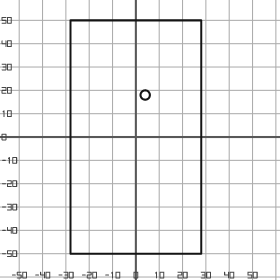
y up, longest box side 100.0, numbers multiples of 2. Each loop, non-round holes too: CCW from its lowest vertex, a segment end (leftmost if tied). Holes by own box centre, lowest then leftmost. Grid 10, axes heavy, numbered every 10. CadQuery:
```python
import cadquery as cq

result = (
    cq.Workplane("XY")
    .moveTo(-28.0, -50.0)
    .lineTo(28.0, -50.0)
    .lineTo(28.0, 50.0)
    .lineTo(-28.0, 50.0)
    .close()
    .moveTo(4.0, 18.0)
    .circle(2.0)
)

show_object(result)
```